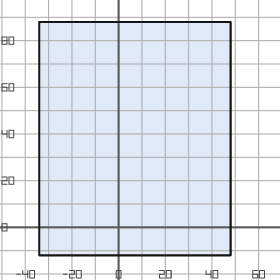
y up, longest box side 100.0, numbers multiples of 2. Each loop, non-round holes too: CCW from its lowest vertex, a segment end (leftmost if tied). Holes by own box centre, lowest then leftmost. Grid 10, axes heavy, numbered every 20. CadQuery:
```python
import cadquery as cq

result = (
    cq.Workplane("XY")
    .moveTo(-34.0, -12.0)
    .lineTo(48.0, -12.0)
    .lineTo(48.0, 88.0)
    .lineTo(-34.0, 88.0)
    .close()
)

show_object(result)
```